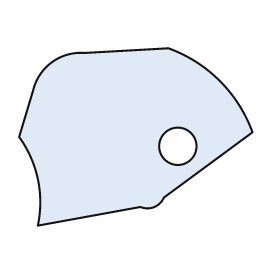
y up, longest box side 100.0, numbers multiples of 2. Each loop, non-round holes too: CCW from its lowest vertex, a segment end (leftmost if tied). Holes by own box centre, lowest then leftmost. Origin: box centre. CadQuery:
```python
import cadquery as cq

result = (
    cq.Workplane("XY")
    .moveTo(-42.0, -38.0)
    .lineTo(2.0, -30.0)
    .threePointArc((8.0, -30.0), (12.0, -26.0))
    .lineTo(50.0, 2.0)
    .threePointArc((36.0, 24.0), (14.0, 38.0))
    .lineTo(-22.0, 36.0)
    .threePointArc((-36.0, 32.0), (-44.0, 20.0))
    .lineTo(-50.0, 0.0)
    .threePointArc((-42.0, -18.0), (-42.0, -38.0))
    .close()
    .moveTo(18.0, -4.0)
    .circle(8.0)
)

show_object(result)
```